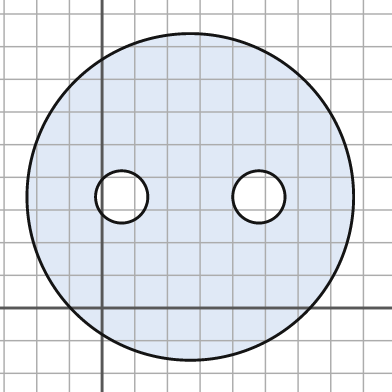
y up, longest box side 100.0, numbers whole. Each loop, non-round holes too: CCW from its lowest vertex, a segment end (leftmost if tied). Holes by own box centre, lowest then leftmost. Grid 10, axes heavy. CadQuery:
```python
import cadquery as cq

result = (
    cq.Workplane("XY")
    .moveTo(27.0, 34.0)
    .circle(50.0)
    .moveTo(6.0, 34.0)
    .circle(8.0)
    .moveTo(48.0, 34.0)
    .circle(8.0)
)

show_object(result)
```